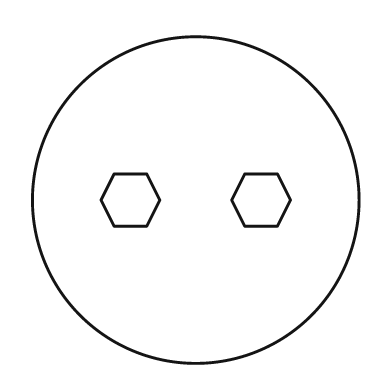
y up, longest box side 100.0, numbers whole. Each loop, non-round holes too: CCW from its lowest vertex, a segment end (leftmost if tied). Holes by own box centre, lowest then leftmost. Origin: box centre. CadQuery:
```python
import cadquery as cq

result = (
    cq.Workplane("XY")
    .moveTo(0.0, 0.0)
    .circle(50.0)
    .moveTo(-25.0, -8.0)
    .lineTo(-15.0, -8.0)
    .lineTo(-11.0, 0.0)
    .lineTo(-15.0, 8.0)
    .lineTo(-25.0, 8.0)
    .lineTo(-29.0, 0.0)
    .close()
    .moveTo(15.0, -8.0)
    .lineTo(25.0, -8.0)
    .lineTo(29.0, 0.0)
    .lineTo(25.0, 8.0)
    .lineTo(15.0, 8.0)
    .lineTo(11.0, 0.0)
    .close()
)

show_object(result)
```